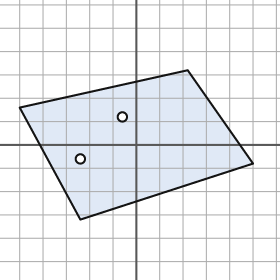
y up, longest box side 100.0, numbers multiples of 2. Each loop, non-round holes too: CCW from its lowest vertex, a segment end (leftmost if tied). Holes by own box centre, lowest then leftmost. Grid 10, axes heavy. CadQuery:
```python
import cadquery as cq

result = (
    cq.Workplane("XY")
    .moveTo(-24.0, -32.0)
    .lineTo(50.0, -8.0)
    .lineTo(22.0, 32.0)
    .lineTo(-50.0, 16.0)
    .close()
    .moveTo(-24.0, -6.0)
    .circle(2.0)
    .moveTo(-6.0, 12.0)
    .circle(2.0)
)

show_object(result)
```